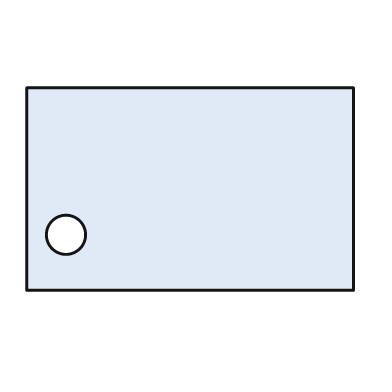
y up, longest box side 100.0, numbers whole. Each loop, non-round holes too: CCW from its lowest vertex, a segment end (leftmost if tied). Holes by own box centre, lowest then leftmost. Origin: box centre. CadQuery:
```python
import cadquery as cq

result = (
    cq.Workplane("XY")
    .moveTo(-50.0, -31.0)
    .lineTo(50.0, -31.0)
    .lineTo(50.0, 31.0)
    .lineTo(-50.0, 31.0)
    .close()
    .moveTo(-38.0, -14.0)
    .circle(6.0)
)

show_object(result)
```